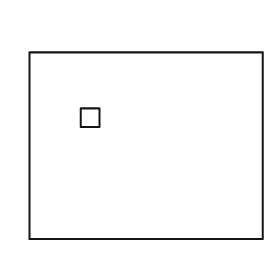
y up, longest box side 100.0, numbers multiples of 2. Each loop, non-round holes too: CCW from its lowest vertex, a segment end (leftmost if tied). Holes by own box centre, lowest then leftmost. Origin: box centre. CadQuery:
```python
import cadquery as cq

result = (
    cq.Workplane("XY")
    .moveTo(-50.0, -40.0)
    .lineTo(50.0, -40.0)
    .lineTo(50.0, 40.0)
    .lineTo(-50.0, 40.0)
    .close()
    .moveTo(-28.0, 8.0)
    .lineTo(-20.0, 8.0)
    .lineTo(-20.0, 16.0)
    .lineTo(-28.0, 16.0)
    .close()
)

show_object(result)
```